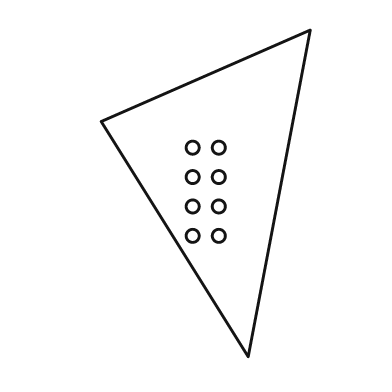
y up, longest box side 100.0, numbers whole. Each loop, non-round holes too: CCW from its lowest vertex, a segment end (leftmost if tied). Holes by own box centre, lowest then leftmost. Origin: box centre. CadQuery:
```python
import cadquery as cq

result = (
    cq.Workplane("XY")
    .moveTo(13.0, -50.0)
    .lineTo(32.0, 50.0)
    .lineTo(-32.0, 22.0)
    .close()
    .moveTo(-4.0, -13.0)
    .circle(2.0)
    .moveTo(4.0, -13.0)
    .circle(2.0)
    .moveTo(-4.0, -4.0)
    .circle(2.0)
    .moveTo(4.0, -4.0)
    .circle(2.0)
    .moveTo(-4.0, 5.0)
    .circle(2.0)
    .moveTo(4.0, 5.0)
    .circle(2.0)
    .moveTo(-4.0, 14.0)
    .circle(2.0)
    .moveTo(4.0, 14.0)
    .circle(2.0)
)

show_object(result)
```